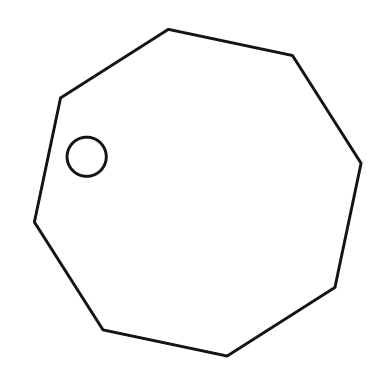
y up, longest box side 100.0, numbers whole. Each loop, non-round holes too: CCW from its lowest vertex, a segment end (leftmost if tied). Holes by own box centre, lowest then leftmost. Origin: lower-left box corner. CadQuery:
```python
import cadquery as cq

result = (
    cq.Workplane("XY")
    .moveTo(59.0, 0.0)
    .lineTo(92.0, 21.0)
    .lineTo(100.0, 59.0)
    .lineTo(79.0, 92.0)
    .lineTo(41.0, 100.0)
    .lineTo(8.0, 79.0)
    .lineTo(0.0, 41.0)
    .lineTo(21.0, 8.0)
    .close()
    .moveTo(16.0, 61.0)
    .circle(6.0)
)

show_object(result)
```